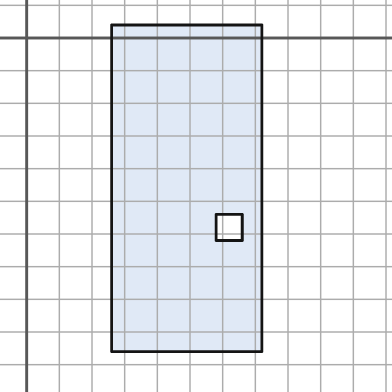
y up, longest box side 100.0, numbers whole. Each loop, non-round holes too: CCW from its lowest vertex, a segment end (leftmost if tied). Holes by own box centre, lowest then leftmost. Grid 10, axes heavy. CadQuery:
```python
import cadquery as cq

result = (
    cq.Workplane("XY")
    .moveTo(26.0, -96.0)
    .lineTo(72.0, -96.0)
    .lineTo(72.0, 4.0)
    .lineTo(26.0, 4.0)
    .close()
    .moveTo(58.0, -62.0)
    .lineTo(66.0, -62.0)
    .lineTo(66.0, -54.0)
    .lineTo(58.0, -54.0)
    .close()
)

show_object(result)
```